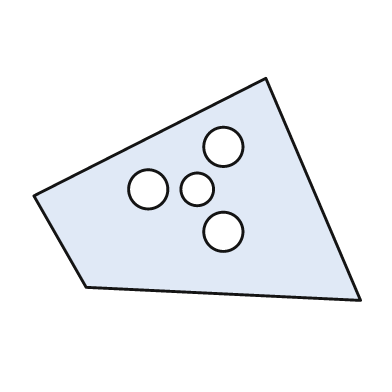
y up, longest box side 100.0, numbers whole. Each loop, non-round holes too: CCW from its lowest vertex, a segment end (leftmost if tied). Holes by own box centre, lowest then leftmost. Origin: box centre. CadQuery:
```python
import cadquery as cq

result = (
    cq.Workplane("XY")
    .moveTo(50.0, -34.0)
    .lineTo(21.0, 34.0)
    .lineTo(-50.0, -2.0)
    .lineTo(-34.0, -30.0)
    .close()
    .moveTo(8.0, -13.0)
    .circle(6.0)
    .moveTo(-15.0, 0.0)
    .circle(6.0)
    .moveTo(0.0, 0.0)
    .circle(5.0)
    .moveTo(8.0, 13.0)
    .circle(6.0)
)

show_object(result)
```